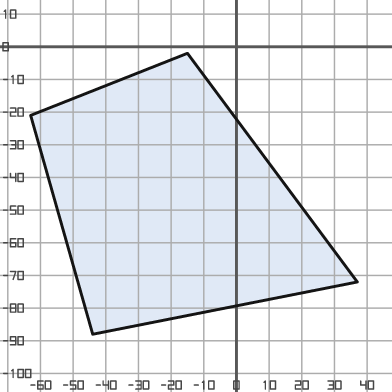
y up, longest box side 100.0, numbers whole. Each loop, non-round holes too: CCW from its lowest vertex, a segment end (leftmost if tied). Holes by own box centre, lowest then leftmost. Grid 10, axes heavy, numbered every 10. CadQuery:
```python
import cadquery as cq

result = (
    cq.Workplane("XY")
    .moveTo(-44.0, -88.0)
    .lineTo(37.0, -72.0)
    .lineTo(-15.0, -2.0)
    .lineTo(-63.0, -21.0)
    .close()
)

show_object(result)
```